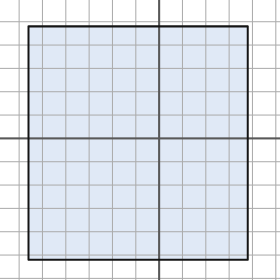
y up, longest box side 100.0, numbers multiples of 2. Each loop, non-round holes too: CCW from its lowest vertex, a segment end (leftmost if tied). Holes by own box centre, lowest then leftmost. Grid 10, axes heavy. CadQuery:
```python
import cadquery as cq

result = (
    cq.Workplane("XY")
    .moveTo(-56.0, -52.0)
    .lineTo(38.0, -52.0)
    .lineTo(38.0, 48.0)
    .lineTo(-56.0, 48.0)
    .close()
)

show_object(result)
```